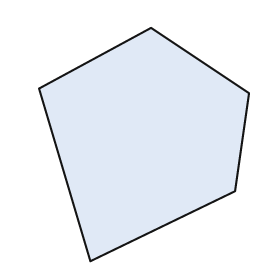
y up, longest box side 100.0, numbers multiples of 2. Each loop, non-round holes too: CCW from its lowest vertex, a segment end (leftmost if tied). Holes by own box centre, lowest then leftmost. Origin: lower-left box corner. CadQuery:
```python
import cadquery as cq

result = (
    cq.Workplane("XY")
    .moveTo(22.0, 0.0)
    .lineTo(84.0, 30.0)
    .lineTo(90.0, 72.0)
    .lineTo(48.0, 100.0)
    .lineTo(0.0, 74.0)
    .close()
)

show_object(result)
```